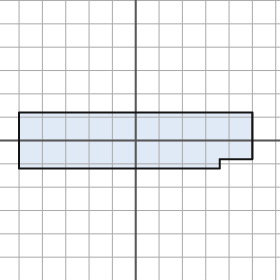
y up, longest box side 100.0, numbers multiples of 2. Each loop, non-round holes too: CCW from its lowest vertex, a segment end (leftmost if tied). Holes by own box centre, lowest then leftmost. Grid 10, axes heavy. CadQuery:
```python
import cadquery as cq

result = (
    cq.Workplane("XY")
    .moveTo(-50.0, -12.0)
    .lineTo(36.0, -12.0)
    .lineTo(36.0, -8.0)
    .lineTo(50.0, -8.0)
    .lineTo(50.0, 12.0)
    .lineTo(-50.0, 12.0)
    .close()
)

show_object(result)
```